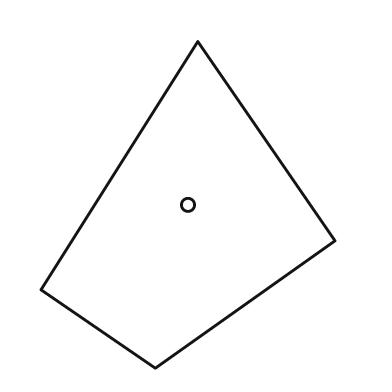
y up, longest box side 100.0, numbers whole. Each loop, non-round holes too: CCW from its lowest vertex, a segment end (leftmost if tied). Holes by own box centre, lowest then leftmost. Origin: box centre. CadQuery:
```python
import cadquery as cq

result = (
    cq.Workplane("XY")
    .moveTo(-10.0, -50.0)
    .lineTo(45.0, -11.0)
    .lineTo(3.0, 50.0)
    .lineTo(-45.0, -26.0)
    .close()
    .moveTo(0.0, 0.0)
    .circle(2.0)
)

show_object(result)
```